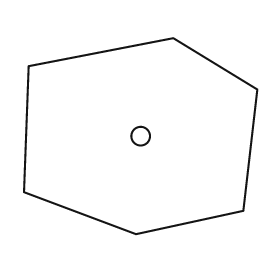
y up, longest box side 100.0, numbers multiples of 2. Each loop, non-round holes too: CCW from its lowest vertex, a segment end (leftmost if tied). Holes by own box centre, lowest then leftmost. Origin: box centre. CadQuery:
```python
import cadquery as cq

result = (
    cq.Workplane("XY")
    .moveTo(-2.0, -42.0)
    .lineTo(44.0, -32.0)
    .lineTo(50.0, 20.0)
    .lineTo(14.0, 42.0)
    .lineTo(-48.0, 30.0)
    .lineTo(-50.0, -24.0)
    .close()
    .moveTo(0.0, 0.0)
    .circle(4.0)
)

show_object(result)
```